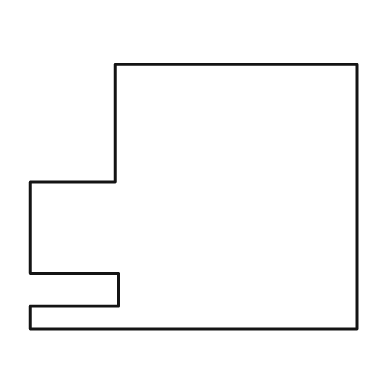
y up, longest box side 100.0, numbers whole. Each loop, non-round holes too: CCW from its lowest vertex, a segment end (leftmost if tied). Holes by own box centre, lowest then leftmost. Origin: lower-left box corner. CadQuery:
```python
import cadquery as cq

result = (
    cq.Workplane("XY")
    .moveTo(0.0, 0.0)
    .lineTo(100.0, 0.0)
    .lineTo(100.0, 81.0)
    .lineTo(26.0, 81.0)
    .lineTo(26.0, 45.0)
    .lineTo(0.0, 45.0)
    .lineTo(0.0, 17.0)
    .lineTo(27.0, 17.0)
    .lineTo(27.0, 7.0)
    .lineTo(0.0, 7.0)
    .close()
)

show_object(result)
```